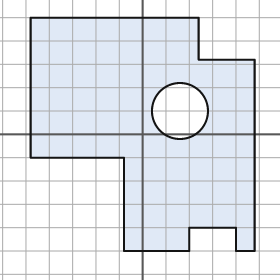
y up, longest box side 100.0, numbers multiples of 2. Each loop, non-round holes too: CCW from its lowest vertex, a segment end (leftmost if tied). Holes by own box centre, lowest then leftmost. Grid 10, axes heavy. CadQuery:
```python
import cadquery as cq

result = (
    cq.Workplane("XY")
    .moveTo(-8.0, -50.0)
    .lineTo(20.0, -50.0)
    .lineTo(20.0, -40.0)
    .lineTo(40.0, -40.0)
    .lineTo(40.0, -50.0)
    .lineTo(48.0, -50.0)
    .lineTo(48.0, 32.0)
    .lineTo(24.0, 32.0)
    .lineTo(24.0, 50.0)
    .lineTo(-48.0, 50.0)
    .lineTo(-48.0, -10.0)
    .lineTo(-8.0, -10.0)
    .close()
    .moveTo(16.0, 10.0)
    .circle(12.0)
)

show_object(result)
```